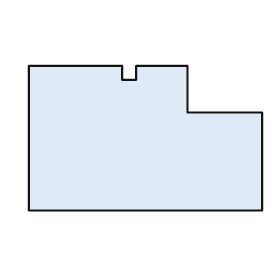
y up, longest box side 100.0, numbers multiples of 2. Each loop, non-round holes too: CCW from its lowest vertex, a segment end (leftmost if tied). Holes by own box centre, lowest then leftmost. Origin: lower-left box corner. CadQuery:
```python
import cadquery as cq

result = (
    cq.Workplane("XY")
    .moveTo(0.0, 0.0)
    .lineTo(100.0, 0.0)
    .lineTo(100.0, 42.0)
    .lineTo(68.0, 42.0)
    .lineTo(68.0, 62.0)
    .lineTo(46.0, 62.0)
    .lineTo(46.0, 56.0)
    .lineTo(40.0, 56.0)
    .lineTo(40.0, 62.0)
    .lineTo(0.0, 62.0)
    .close()
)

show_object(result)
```